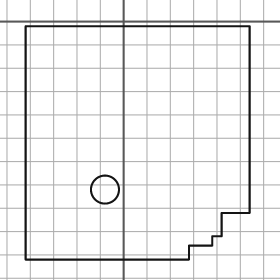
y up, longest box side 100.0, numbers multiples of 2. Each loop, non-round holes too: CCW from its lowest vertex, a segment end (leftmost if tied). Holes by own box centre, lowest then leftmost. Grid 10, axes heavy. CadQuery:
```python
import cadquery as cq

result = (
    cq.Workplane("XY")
    .moveTo(-42.0, -102.0)
    .lineTo(28.0, -102.0)
    .lineTo(28.0, -96.0)
    .lineTo(38.0, -96.0)
    .lineTo(38.0, -92.0)
    .lineTo(42.0, -92.0)
    .lineTo(42.0, -82.0)
    .lineTo(54.0, -82.0)
    .lineTo(54.0, -2.0)
    .lineTo(-42.0, -2.0)
    .close()
    .moveTo(-8.0, -72.0)
    .circle(6.0)
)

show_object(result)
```